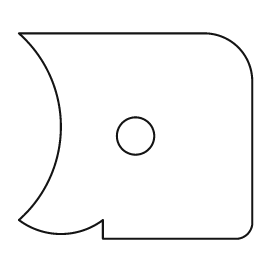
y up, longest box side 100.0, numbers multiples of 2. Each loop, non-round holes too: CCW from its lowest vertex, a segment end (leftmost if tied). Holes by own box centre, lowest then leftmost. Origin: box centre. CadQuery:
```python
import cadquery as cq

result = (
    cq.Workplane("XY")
    .moveTo(-14.0, -44.0)
    .lineTo(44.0, -44.0)
    .threePointArc((48.0, -42.0), (50.0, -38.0))
    .lineTo(50.0, 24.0)
    .threePointArc((44.0, 38.0), (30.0, 44.0))
    .lineTo(-50.0, 44.0)
    .threePointArc((-32.0, 4.0), (-50.0, -36.0))
    .threePointArc((-32.0, -42.0), (-14.0, -36.0))
    .close()
    .moveTo(0.0, 0.0)
    .circle(8.0)
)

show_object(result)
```